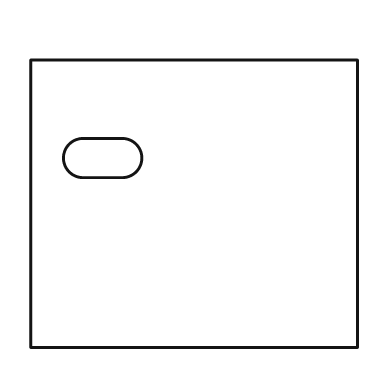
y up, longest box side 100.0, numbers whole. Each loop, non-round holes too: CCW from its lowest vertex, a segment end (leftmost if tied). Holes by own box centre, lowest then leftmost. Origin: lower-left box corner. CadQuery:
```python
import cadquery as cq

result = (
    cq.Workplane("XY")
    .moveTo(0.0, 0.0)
    .lineTo(100.0, 0.0)
    .lineTo(100.0, 88.0)
    .lineTo(0.0, 88.0)
    .close()
    .moveTo(16.0, 52.0)
    .lineTo(28.0, 52.0)
    .threePointArc((34.0, 58.0), (28.0, 64.0))
    .lineTo(16.0, 64.0)
    .threePointArc((10.0, 58.0), (16.0, 52.0))
    .close()
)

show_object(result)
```